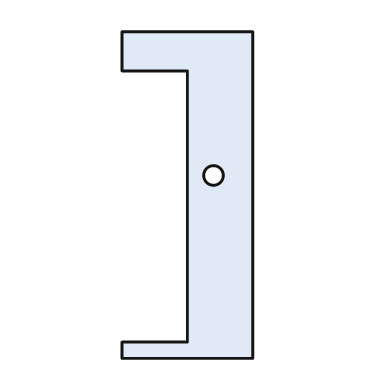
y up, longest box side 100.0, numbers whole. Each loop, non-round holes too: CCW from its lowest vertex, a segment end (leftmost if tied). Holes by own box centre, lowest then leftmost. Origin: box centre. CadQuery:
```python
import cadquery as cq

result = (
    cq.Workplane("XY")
    .moveTo(-20.0, -50.0)
    .lineTo(20.0, -50.0)
    .lineTo(20.0, 50.0)
    .lineTo(-20.0, 50.0)
    .lineTo(-20.0, 38.0)
    .lineTo(0.0, 38.0)
    .lineTo(0.0, -45.0)
    .lineTo(-20.0, -45.0)
    .close()
    .moveTo(8.0, 6.0)
    .circle(3.0)
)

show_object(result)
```